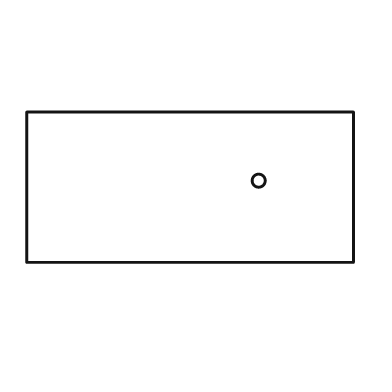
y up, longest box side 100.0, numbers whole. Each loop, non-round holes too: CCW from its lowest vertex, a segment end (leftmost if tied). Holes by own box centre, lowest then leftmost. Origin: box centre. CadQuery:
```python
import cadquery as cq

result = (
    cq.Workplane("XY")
    .moveTo(-50.0, -23.0)
    .lineTo(50.0, -23.0)
    .lineTo(50.0, 23.0)
    .lineTo(-50.0, 23.0)
    .close()
    .moveTo(21.0, 2.0)
    .circle(2.0)
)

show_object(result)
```